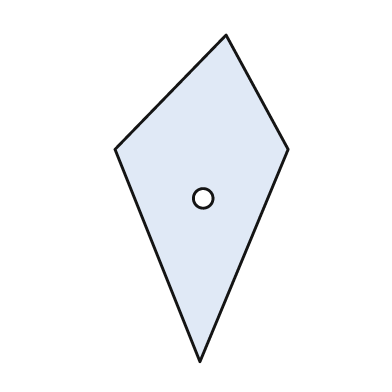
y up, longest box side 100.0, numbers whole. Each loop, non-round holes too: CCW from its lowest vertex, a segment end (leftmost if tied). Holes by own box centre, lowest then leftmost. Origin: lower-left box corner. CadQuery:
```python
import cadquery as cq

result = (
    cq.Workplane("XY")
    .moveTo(26.0, 0.0)
    .lineTo(53.0, 65.0)
    .lineTo(34.0, 100.0)
    .lineTo(0.0, 65.0)
    .close()
    .moveTo(27.0, 50.0)
    .circle(3.0)
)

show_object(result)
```